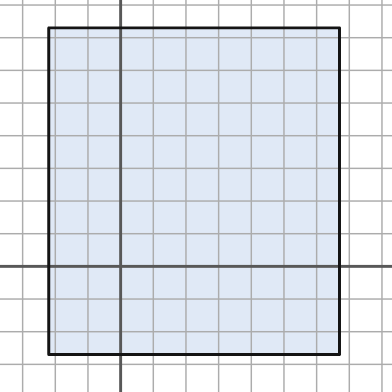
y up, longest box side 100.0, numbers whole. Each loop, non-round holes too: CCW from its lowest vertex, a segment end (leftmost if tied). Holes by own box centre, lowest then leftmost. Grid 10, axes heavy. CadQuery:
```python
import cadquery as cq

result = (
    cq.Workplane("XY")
    .moveTo(-22.0, -27.0)
    .lineTo(67.0, -27.0)
    .lineTo(67.0, 73.0)
    .lineTo(-22.0, 73.0)
    .close()
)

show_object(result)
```